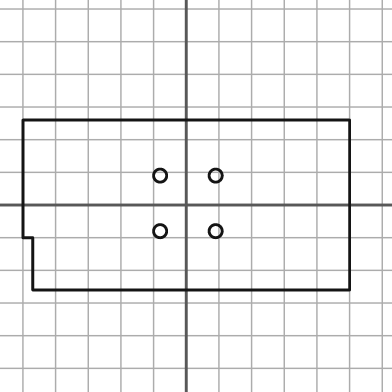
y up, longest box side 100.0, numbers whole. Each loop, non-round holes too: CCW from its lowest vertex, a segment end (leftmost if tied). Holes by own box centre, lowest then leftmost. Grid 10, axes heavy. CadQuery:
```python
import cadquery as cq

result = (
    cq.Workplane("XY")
    .moveTo(-47.0, -26.0)
    .lineTo(50.0, -26.0)
    .lineTo(50.0, 26.0)
    .lineTo(-50.0, 26.0)
    .lineTo(-50.0, -10.0)
    .lineTo(-47.0, -10.0)
    .close()
    .moveTo(-8.0, -8.0)
    .circle(2.0)
    .moveTo(9.0, -8.0)
    .circle(2.0)
    .moveTo(-8.0, 9.0)
    .circle(2.0)
    .moveTo(9.0, 9.0)
    .circle(2.0)
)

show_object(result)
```